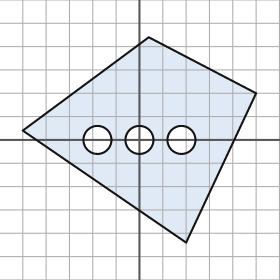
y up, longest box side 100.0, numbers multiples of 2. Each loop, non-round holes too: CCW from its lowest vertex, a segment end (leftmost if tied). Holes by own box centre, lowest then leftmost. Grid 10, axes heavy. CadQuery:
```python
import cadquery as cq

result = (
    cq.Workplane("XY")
    .moveTo(20.0, -44.0)
    .lineTo(50.0, 20.0)
    .lineTo(4.0, 44.0)
    .lineTo(-50.0, 4.0)
    .close()
    .moveTo(-18.0, 0.0)
    .circle(6.0)
    .moveTo(0.0, 0.0)
    .circle(6.0)
    .moveTo(18.0, 0.0)
    .circle(6.0)
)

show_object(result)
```